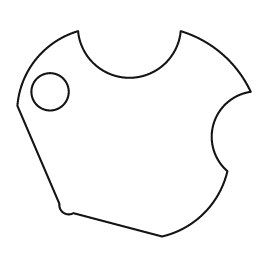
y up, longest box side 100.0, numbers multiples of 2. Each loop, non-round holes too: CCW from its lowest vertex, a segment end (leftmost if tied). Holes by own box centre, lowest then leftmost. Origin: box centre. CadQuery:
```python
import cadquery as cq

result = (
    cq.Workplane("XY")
    .moveTo(12.0, -44.0)
    .threePointArc((30.0, -34.0), (40.0, -16.0))
    .threePointArc((34.0, 4.0), (50.0, 18.0))
    .threePointArc((38.0, 34.0), (20.0, 44.0))
    .threePointArc((-2.0, 24.0), (-24.0, 44.0))
    .threePointArc((-42.0, 32.0), (-50.0, 12.0))
    .lineTo(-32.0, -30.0)
    .threePointArc((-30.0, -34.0), (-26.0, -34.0))
    .close()
    .moveTo(-36.0, 18.0)
    .circle(8.0)
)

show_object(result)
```